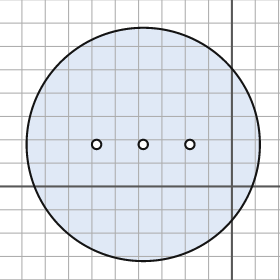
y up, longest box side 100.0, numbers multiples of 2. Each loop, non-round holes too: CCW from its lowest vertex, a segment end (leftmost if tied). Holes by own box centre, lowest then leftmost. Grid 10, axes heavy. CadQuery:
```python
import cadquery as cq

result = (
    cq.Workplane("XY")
    .moveTo(-38.0, 18.0)
    .circle(50.0)
    .moveTo(-58.0, 18.0)
    .circle(2.0)
    .moveTo(-38.0, 18.0)
    .circle(2.0)
    .moveTo(-18.0, 18.0)
    .circle(2.0)
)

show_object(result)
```